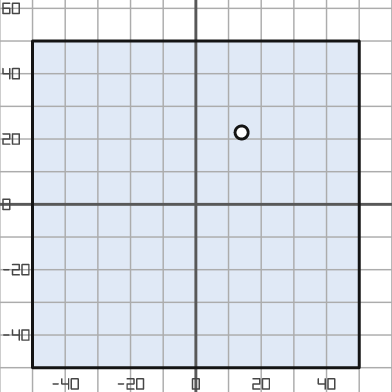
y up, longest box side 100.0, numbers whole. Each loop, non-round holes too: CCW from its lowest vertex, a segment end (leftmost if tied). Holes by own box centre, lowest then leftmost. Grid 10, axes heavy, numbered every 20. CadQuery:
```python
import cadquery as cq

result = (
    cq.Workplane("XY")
    .moveTo(-50.0, -50.0)
    .lineTo(50.0, -50.0)
    .lineTo(50.0, 50.0)
    .lineTo(-50.0, 50.0)
    .close()
    .moveTo(14.0, 22.0)
    .circle(2.0)
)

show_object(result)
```